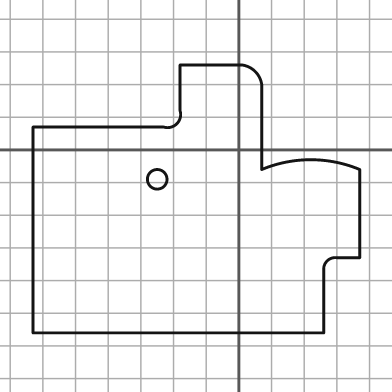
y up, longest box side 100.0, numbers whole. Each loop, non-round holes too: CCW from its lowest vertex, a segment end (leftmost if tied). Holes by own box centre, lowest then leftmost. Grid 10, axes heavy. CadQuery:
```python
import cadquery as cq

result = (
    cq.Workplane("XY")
    .moveTo(-63.0, -56.0)
    .lineTo(26.0, -56.0)
    .lineTo(26.0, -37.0)
    .threePointArc((27.0, -34.0), (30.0, -33.0))
    .lineTo(37.0, -33.0)
    .lineTo(37.0, -6.0)
    .threePointArc((22.0, -3.0), (7.0, -6.0))
    .lineTo(7.0, 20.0)
    .threePointArc((5.0, 24.0), (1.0, 26.0))
    .lineTo(-18.0, 26.0)
    .lineTo(-18.0, 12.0)
    .threePointArc((-19.0, 8.0), (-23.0, 7.0))
    .lineTo(-63.0, 7.0)
    .close()
    .moveTo(-25.0, -9.0)
    .circle(3.0)
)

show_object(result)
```